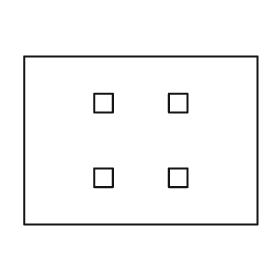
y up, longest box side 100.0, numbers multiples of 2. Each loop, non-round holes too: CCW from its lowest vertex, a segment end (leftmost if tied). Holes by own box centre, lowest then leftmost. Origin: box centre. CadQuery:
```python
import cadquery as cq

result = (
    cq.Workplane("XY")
    .moveTo(-50.0, -36.0)
    .lineTo(50.0, -36.0)
    .lineTo(50.0, 36.0)
    .lineTo(-50.0, 36.0)
    .close()
    .moveTo(-20.0, -20.0)
    .lineTo(-12.0, -20.0)
    .lineTo(-12.0, -12.0)
    .lineTo(-20.0, -12.0)
    .close()
    .moveTo(12.0, -20.0)
    .lineTo(20.0, -20.0)
    .lineTo(20.0, -12.0)
    .lineTo(12.0, -12.0)
    .close()
    .moveTo(-20.0, 12.0)
    .lineTo(-12.0, 12.0)
    .lineTo(-12.0, 20.0)
    .lineTo(-20.0, 20.0)
    .close()
    .moveTo(12.0, 12.0)
    .lineTo(20.0, 12.0)
    .lineTo(20.0, 20.0)
    .lineTo(12.0, 20.0)
    .close()
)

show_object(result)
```